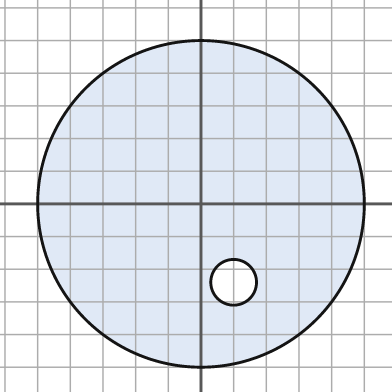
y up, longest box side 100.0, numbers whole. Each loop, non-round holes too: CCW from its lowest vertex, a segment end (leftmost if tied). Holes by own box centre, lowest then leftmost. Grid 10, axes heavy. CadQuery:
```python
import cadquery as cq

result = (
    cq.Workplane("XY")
    .moveTo(0.0, 0.0)
    .circle(50.0)
    .moveTo(10.0, -24.0)
    .circle(7.0)
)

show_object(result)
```